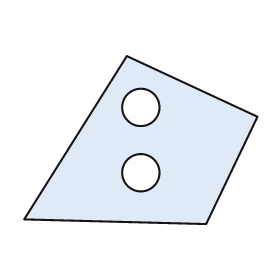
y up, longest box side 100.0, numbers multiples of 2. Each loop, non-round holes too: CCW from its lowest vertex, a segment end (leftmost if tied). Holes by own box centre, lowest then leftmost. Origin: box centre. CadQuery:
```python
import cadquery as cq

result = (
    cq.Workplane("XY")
    .moveTo(28.0, -36.0)
    .lineTo(50.0, 10.0)
    .lineTo(-6.0, 36.0)
    .lineTo(-50.0, -34.0)
    .close()
    .moveTo(0.0, -14.0)
    .circle(8.0)
    .moveTo(0.0, 14.0)
    .circle(8.0)
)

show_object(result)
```